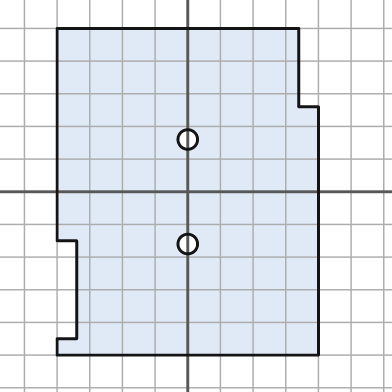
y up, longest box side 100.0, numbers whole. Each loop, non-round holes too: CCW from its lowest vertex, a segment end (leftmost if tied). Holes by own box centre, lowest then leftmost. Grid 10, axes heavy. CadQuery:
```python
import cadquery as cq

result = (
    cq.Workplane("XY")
    .moveTo(-40.0, -50.0)
    .lineTo(40.0, -50.0)
    .lineTo(40.0, 26.0)
    .lineTo(34.0, 26.0)
    .lineTo(34.0, 50.0)
    .lineTo(-40.0, 50.0)
    .lineTo(-40.0, -15.0)
    .lineTo(-34.0, -15.0)
    .lineTo(-34.0, -45.0)
    .lineTo(-40.0, -45.0)
    .close()
    .moveTo(0.0, -16.0)
    .circle(3.0)
    .moveTo(0.0, 16.0)
    .circle(3.0)
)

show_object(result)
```